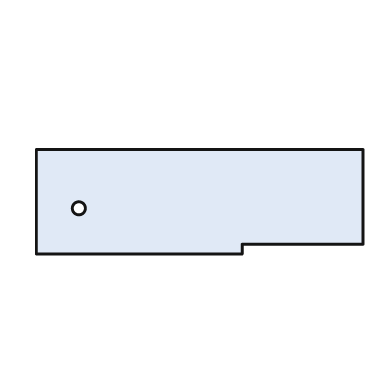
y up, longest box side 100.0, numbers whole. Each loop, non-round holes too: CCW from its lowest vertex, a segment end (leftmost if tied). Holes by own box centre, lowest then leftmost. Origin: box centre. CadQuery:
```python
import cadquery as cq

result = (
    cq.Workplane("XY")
    .moveTo(-50.0, -16.0)
    .lineTo(13.0, -16.0)
    .lineTo(13.0, -13.0)
    .lineTo(50.0, -13.0)
    .lineTo(50.0, 16.0)
    .lineTo(-50.0, 16.0)
    .close()
    .moveTo(-37.0, -2.0)
    .circle(2.0)
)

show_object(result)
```